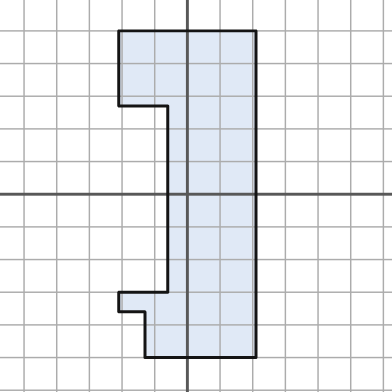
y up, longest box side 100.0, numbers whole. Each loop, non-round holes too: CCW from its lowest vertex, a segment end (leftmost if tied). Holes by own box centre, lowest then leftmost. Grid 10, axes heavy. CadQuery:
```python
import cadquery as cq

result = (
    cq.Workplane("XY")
    .moveTo(-13.0, -50.0)
    .lineTo(21.0, -50.0)
    .lineTo(21.0, 50.0)
    .lineTo(-21.0, 50.0)
    .lineTo(-21.0, 27.0)
    .lineTo(-6.0, 27.0)
    .lineTo(-6.0, -30.0)
    .lineTo(-21.0, -30.0)
    .lineTo(-21.0, -36.0)
    .lineTo(-13.0, -36.0)
    .close()
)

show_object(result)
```